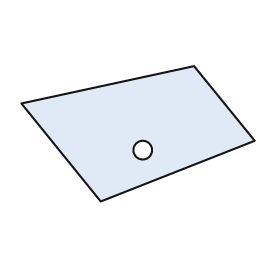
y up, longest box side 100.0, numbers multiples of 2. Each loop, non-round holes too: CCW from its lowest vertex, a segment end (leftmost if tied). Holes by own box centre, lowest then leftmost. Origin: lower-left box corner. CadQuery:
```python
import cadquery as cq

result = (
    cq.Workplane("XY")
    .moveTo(34.0, 0.0)
    .lineTo(100.0, 26.0)
    .lineTo(74.0, 58.0)
    .lineTo(0.0, 42.0)
    .close()
    .moveTo(52.0, 22.0)
    .circle(4.0)
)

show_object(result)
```